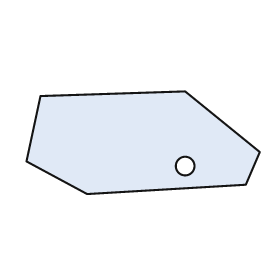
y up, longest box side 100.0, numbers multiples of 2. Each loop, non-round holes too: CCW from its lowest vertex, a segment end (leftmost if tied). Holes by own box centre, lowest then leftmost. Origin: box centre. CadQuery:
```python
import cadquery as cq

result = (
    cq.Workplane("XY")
    .moveTo(-24.0, -22.0)
    .lineTo(44.0, -18.0)
    .lineTo(50.0, -4.0)
    .lineTo(18.0, 22.0)
    .lineTo(-44.0, 20.0)
    .lineTo(-50.0, -8.0)
    .close()
    .moveTo(18.0, -10.0)
    .circle(4.0)
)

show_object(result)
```